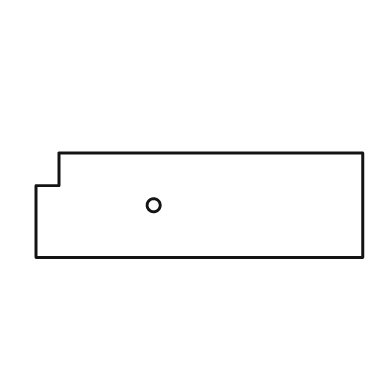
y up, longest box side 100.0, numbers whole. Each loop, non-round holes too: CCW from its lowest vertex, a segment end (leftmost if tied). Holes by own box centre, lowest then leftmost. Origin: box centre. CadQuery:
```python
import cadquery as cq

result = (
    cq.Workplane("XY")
    .moveTo(-50.0, -16.0)
    .lineTo(50.0, -16.0)
    .lineTo(50.0, 16.0)
    .lineTo(-43.0, 16.0)
    .lineTo(-43.0, 6.0)
    .lineTo(-50.0, 6.0)
    .close()
    .moveTo(-14.0, 0.0)
    .circle(2.0)
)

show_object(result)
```